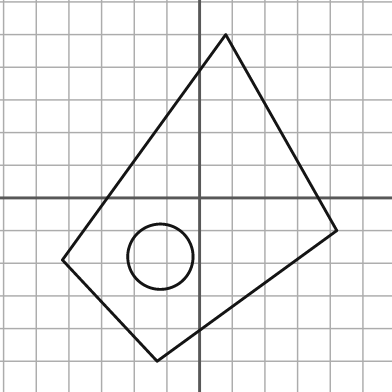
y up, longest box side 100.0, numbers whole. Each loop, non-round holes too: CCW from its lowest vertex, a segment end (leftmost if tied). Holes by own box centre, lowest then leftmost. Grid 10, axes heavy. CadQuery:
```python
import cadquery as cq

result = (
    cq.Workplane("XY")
    .moveTo(-13.0, -50.0)
    .lineTo(42.0, -10.0)
    .lineTo(8.0, 50.0)
    .lineTo(-42.0, -19.0)
    .close()
    .moveTo(-12.0, -18.0)
    .circle(10.0)
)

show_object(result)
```